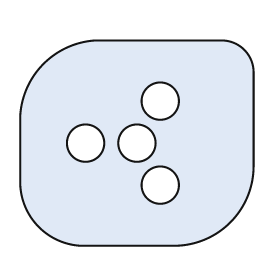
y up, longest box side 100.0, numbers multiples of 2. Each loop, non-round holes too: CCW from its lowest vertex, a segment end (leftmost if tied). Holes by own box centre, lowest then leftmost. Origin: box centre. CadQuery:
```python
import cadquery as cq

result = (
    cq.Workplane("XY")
    .moveTo(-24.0, -44.0)
    .lineTo(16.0, -44.0)
    .threePointArc((40.0, -34.0), (50.0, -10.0))
    .lineTo(50.0, 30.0)
    .threePointArc((46.0, 40.0), (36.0, 44.0))
    .lineTo(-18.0, 44.0)
    .threePointArc((-40.0, 34.0), (-50.0, 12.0))
    .lineTo(-50.0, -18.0)
    .threePointArc((-42.0, -36.0), (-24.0, -44.0))
    .close()
    .moveTo(10.0, -18.0)
    .circle(8.0)
    .moveTo(-22.0, 0.0)
    .circle(8.0)
    .moveTo(0.0, 0.0)
    .circle(8.0)
    .moveTo(10.0, 18.0)
    .circle(8.0)
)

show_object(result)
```